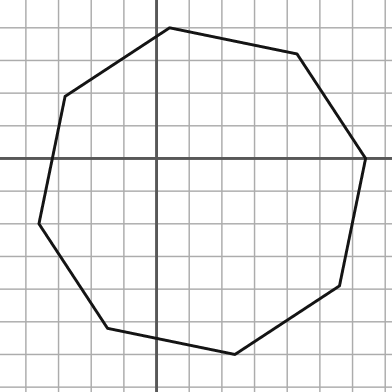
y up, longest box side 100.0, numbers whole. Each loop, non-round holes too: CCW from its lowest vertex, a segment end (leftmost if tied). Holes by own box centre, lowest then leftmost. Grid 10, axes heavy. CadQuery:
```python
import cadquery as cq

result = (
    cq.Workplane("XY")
    .moveTo(24.0, -60.0)
    .lineTo(56.0, -39.0)
    .lineTo(64.0, 0.0)
    .lineTo(43.0, 32.0)
    .lineTo(4.0, 40.0)
    .lineTo(-28.0, 19.0)
    .lineTo(-36.0, -20.0)
    .lineTo(-15.0, -52.0)
    .close()
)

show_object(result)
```